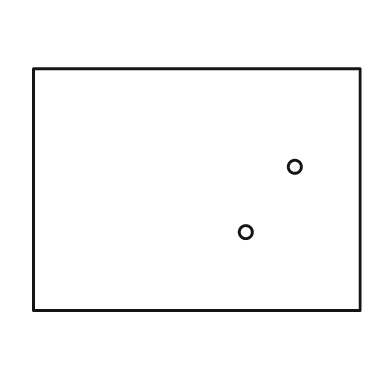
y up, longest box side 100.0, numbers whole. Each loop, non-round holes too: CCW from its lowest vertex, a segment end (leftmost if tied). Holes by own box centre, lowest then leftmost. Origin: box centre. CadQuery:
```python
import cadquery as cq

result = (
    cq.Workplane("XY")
    .moveTo(-50.0, -37.0)
    .lineTo(50.0, -37.0)
    .lineTo(50.0, 37.0)
    .lineTo(-50.0, 37.0)
    .close()
    .moveTo(15.0, -13.0)
    .circle(2.0)
    .moveTo(30.0, 7.0)
    .circle(2.0)
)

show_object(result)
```